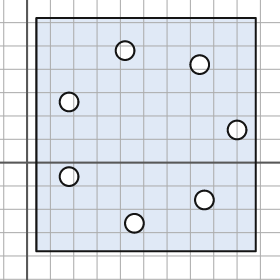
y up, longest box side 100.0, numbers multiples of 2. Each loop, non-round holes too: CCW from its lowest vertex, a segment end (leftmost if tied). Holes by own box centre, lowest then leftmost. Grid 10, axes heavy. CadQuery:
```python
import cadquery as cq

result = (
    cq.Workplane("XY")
    .moveTo(4.0, -38.0)
    .lineTo(98.0, -38.0)
    .lineTo(98.0, 62.0)
    .lineTo(4.0, 62.0)
    .close()
    .moveTo(46.0, -26.0)
    .circle(4.0)
    .moveTo(76.0, -16.0)
    .circle(4.0)
    .moveTo(18.0, -6.0)
    .circle(4.0)
    .moveTo(90.0, 14.0)
    .circle(4.0)
    .moveTo(18.0, 26.0)
    .circle(4.0)
    .moveTo(74.0, 42.0)
    .circle(4.0)
    .moveTo(42.0, 48.0)
    .circle(4.0)
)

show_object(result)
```